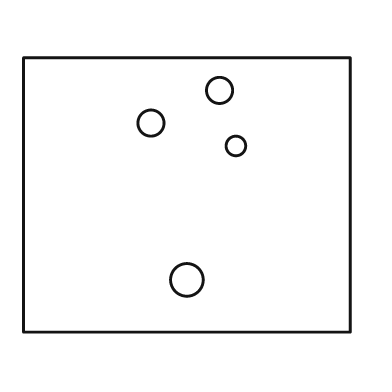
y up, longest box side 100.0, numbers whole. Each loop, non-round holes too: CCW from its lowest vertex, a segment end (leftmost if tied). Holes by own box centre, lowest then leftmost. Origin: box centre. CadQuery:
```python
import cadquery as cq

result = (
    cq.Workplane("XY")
    .moveTo(-50.0, -42.0)
    .lineTo(50.0, -42.0)
    .lineTo(50.0, 42.0)
    .lineTo(-50.0, 42.0)
    .close()
    .moveTo(0.0, -26.0)
    .circle(5.0)
    .moveTo(15.0, 15.0)
    .circle(3.0)
    .moveTo(-11.0, 22.0)
    .circle(4.0)
    .moveTo(10.0, 32.0)
    .circle(4.0)
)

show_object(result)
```